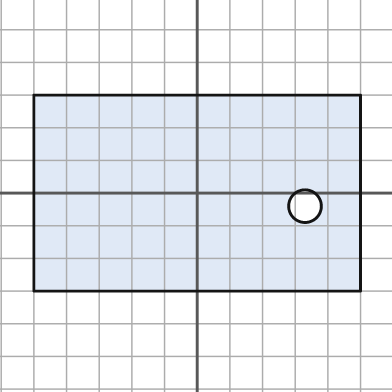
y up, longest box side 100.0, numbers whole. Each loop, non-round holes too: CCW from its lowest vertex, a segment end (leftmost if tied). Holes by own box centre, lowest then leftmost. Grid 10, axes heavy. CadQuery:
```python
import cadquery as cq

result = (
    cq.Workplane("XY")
    .moveTo(-50.0, -30.0)
    .lineTo(50.0, -30.0)
    .lineTo(50.0, 30.0)
    .lineTo(-50.0, 30.0)
    .close()
    .moveTo(33.0, -4.0)
    .circle(5.0)
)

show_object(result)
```